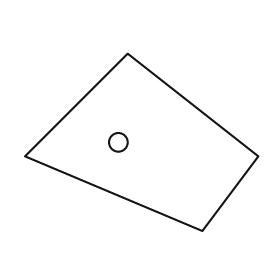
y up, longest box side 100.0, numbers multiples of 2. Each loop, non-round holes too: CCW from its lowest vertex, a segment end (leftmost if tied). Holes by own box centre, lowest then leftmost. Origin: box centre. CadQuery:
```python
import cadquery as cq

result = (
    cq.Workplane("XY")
    .moveTo(26.0, -38.0)
    .lineTo(50.0, -6.0)
    .lineTo(-6.0, 38.0)
    .lineTo(-50.0, -6.0)
    .close()
    .moveTo(-10.0, 0.0)
    .circle(4.0)
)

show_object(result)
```